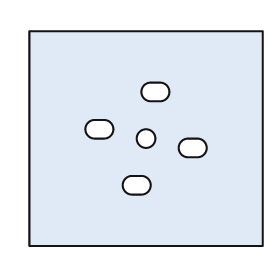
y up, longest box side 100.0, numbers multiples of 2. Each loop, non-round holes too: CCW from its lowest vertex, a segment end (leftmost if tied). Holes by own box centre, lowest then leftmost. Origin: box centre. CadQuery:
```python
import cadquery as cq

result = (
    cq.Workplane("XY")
    .moveTo(-50.0, -46.0)
    .lineTo(50.0, -46.0)
    .lineTo(50.0, 46.0)
    .lineTo(-50.0, 46.0)
    .close()
    .moveTo(-6.0, -24.0)
    .lineTo(-2.0, -24.0)
    .threePointArc((2.0, -20.0), (-2.0, -16.0))
    .lineTo(-6.0, -16.0)
    .threePointArc((-10.0, -20.0), (-6.0, -24.0))
    .close()
    .moveTo(18.0, -8.0)
    .lineTo(22.0, -8.0)
    .threePointArc((26.0, -4.0), (22.0, 0.0))
    .lineTo(18.0, 0.0)
    .threePointArc((14.0, -4.0), (18.0, -8.0))
    .close()
    .moveTo(0.0, 0.0)
    .circle(4.0)
    .moveTo(-22.0, 0.0)
    .lineTo(-18.0, 0.0)
    .threePointArc((-14.0, 4.0), (-18.0, 8.0))
    .lineTo(-22.0, 8.0)
    .threePointArc((-26.0, 4.0), (-22.0, 0.0))
    .close()
    .moveTo(2.0, 16.0)
    .lineTo(6.0, 16.0)
    .threePointArc((10.0, 20.0), (6.0, 24.0))
    .lineTo(2.0, 24.0)
    .threePointArc((-2.0, 20.0), (2.0, 16.0))
    .close()
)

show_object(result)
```